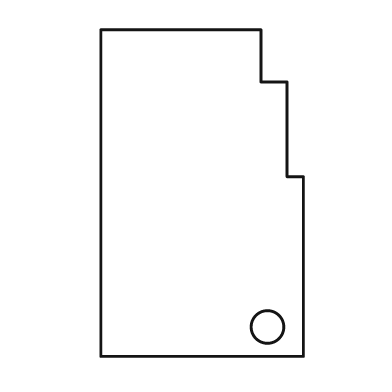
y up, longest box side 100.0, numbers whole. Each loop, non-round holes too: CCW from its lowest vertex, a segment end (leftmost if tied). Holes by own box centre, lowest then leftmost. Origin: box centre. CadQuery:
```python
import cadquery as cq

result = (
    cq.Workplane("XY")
    .moveTo(-31.0, -50.0)
    .lineTo(31.0, -50.0)
    .lineTo(31.0, 5.0)
    .lineTo(26.0, 5.0)
    .lineTo(26.0, 34.0)
    .lineTo(18.0, 34.0)
    .lineTo(18.0, 50.0)
    .lineTo(-31.0, 50.0)
    .close()
    .moveTo(20.0, -41.0)
    .circle(5.0)
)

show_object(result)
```